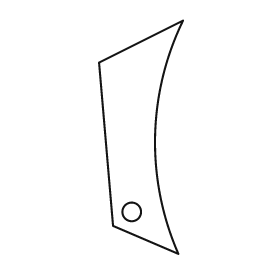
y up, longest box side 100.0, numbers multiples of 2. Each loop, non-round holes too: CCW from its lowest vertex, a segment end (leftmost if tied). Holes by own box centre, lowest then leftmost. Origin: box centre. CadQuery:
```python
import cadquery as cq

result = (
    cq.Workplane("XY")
    .moveTo(16.0, -50.0)
    .threePointArc((6.0, 0.0), (18.0, 50.0))
    .lineTo(-18.0, 32.0)
    .lineTo(-12.0, -38.0)
    .close()
    .moveTo(-4.0, -32.0)
    .circle(4.0)
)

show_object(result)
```